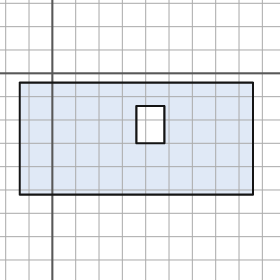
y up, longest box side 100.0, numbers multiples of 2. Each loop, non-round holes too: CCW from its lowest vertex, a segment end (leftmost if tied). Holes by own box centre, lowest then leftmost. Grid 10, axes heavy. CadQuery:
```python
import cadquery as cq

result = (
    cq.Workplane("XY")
    .moveTo(-14.0, -52.0)
    .lineTo(86.0, -52.0)
    .lineTo(86.0, -4.0)
    .lineTo(-14.0, -4.0)
    .close()
    .moveTo(36.0, -30.0)
    .lineTo(48.0, -30.0)
    .lineTo(48.0, -14.0)
    .lineTo(36.0, -14.0)
    .close()
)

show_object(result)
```